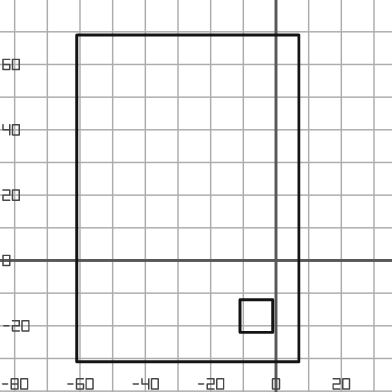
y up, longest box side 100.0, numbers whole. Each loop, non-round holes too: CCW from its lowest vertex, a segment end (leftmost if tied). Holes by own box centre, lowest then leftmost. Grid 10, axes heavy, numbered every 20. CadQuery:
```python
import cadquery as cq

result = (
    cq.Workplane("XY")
    .moveTo(-61.0, -31.0)
    .lineTo(7.0, -31.0)
    .lineTo(7.0, 69.0)
    .lineTo(-61.0, 69.0)
    .close()
    .moveTo(-11.0, -22.0)
    .lineTo(-1.0, -22.0)
    .lineTo(-1.0, -12.0)
    .lineTo(-11.0, -12.0)
    .close()
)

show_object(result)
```